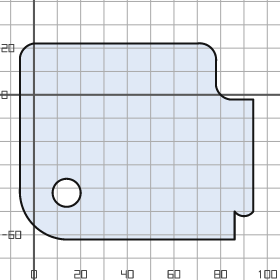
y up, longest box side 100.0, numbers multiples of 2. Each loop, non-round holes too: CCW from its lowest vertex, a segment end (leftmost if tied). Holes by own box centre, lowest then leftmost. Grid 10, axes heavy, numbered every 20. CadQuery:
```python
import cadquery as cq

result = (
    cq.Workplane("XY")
    .moveTo(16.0, -62.0)
    .lineTo(86.0, -62.0)
    .lineTo(86.0, -50.0)
    .threePointArc((90.0, -52.0), (94.0, -50.0))
    .lineTo(94.0, -2.0)
    .lineTo(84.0, -2.0)
    .threePointArc((80.0, 0.0), (78.0, 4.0))
    .lineTo(78.0, 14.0)
    .threePointArc((76.0, 20.0), (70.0, 22.0))
    .lineTo(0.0, 22.0)
    .threePointArc((-4.0, 20.0), (-6.0, 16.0))
    .lineTo(-6.0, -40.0)
    .threePointArc((0.0, -56.0), (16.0, -62.0))
    .close()
    .moveTo(14.0, -42.0)
    .circle(6.0)
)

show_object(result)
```